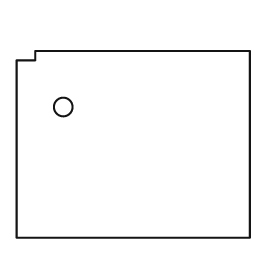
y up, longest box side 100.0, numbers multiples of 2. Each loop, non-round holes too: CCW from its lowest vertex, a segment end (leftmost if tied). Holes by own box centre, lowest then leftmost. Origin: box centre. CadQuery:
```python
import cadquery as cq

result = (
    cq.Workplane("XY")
    .moveTo(-50.0, -40.0)
    .lineTo(50.0, -40.0)
    .lineTo(50.0, 40.0)
    .lineTo(-42.0, 40.0)
    .lineTo(-42.0, 36.0)
    .lineTo(-50.0, 36.0)
    .close()
    .moveTo(-30.0, 16.0)
    .circle(4.0)
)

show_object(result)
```